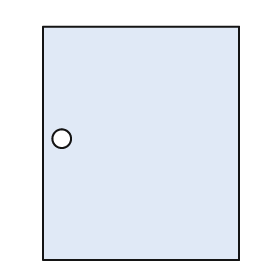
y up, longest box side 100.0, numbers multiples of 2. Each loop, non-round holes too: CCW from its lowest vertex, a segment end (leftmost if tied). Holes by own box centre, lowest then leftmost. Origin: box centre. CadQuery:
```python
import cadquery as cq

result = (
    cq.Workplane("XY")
    .moveTo(-42.0, -50.0)
    .lineTo(42.0, -50.0)
    .lineTo(42.0, 50.0)
    .lineTo(-42.0, 50.0)
    .close()
    .moveTo(-34.0, 2.0)
    .circle(4.0)
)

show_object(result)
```